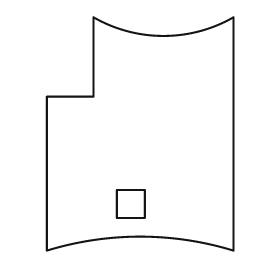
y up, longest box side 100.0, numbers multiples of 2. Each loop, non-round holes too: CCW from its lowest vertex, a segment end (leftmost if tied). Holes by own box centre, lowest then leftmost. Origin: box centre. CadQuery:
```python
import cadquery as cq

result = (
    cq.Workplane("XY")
    .moveTo(-40.0, -50.0)
    .threePointArc((0.0, -44.0), (40.0, -50.0))
    .lineTo(40.0, 50.0)
    .threePointArc((10.0, 42.0), (-20.0, 50.0))
    .lineTo(-20.0, 16.0)
    .lineTo(-40.0, 16.0)
    .close()
    .moveTo(-10.0, -36.0)
    .lineTo(2.0, -36.0)
    .lineTo(2.0, -24.0)
    .lineTo(-10.0, -24.0)
    .close()
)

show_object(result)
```